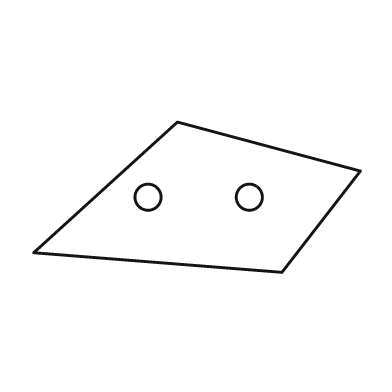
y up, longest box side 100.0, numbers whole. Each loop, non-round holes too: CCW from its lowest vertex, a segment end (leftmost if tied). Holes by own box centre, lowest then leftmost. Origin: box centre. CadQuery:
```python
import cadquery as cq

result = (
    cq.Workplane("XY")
    .moveTo(26.0, -23.0)
    .lineTo(50.0, 8.0)
    .lineTo(-6.0, 23.0)
    .lineTo(-50.0, -17.0)
    .close()
    .moveTo(-15.0, 0.0)
    .circle(4.0)
    .moveTo(16.0, 0.0)
    .circle(4.0)
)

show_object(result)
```